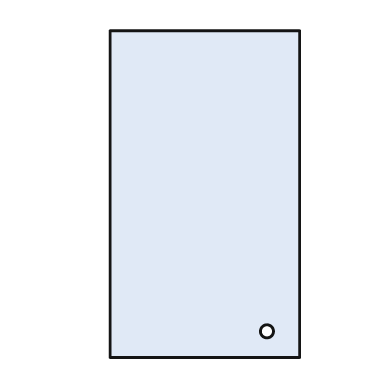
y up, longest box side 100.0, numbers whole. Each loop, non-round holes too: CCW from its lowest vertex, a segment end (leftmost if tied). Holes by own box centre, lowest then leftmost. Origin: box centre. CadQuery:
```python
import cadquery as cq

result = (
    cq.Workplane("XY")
    .moveTo(-29.0, -50.0)
    .lineTo(29.0, -50.0)
    .lineTo(29.0, 50.0)
    .lineTo(-29.0, 50.0)
    .close()
    .moveTo(19.0, -42.0)
    .circle(2.0)
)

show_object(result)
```